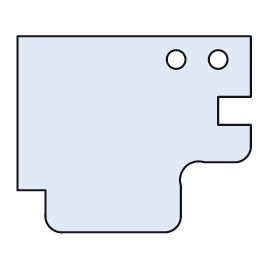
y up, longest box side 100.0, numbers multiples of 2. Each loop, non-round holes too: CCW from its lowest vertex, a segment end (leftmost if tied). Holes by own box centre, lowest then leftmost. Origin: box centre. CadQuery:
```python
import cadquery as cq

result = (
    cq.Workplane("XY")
    .moveTo(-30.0, -42.0)
    .lineTo(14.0, -42.0)
    .threePointArc((18.0, -40.0), (20.0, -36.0))
    .lineTo(20.0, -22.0)
    .threePointArc((22.0, -14.0), (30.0, -12.0))
    .lineTo(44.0, -12.0)
    .threePointArc((48.0, -10.0), (50.0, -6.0))
    .lineTo(50.0, 4.0)
    .lineTo(36.0, 4.0)
    .lineTo(36.0, 16.0)
    .lineTo(50.0, 16.0)
    .lineTo(50.0, 42.0)
    .lineTo(-50.0, 42.0)
    .lineTo(-50.0, -24.0)
    .lineTo(-38.0, -24.0)
    .lineTo(-38.0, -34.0)
    .threePointArc((-36.0, -40.0), (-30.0, -42.0))
    .close()
    .moveTo(18.0, 32.0)
    .circle(4.0)
    .moveTo(36.0, 32.0)
    .circle(4.0)
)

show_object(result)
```